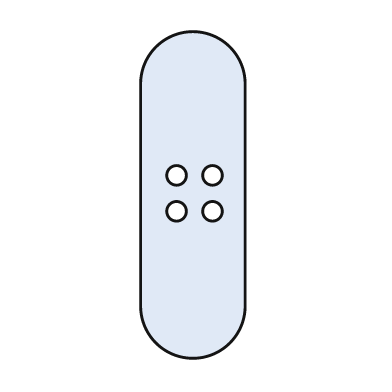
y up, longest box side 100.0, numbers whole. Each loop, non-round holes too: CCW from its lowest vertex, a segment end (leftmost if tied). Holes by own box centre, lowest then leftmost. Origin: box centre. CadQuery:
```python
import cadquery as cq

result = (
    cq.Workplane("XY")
    .moveTo(-16.0, -34.0)
    .threePointArc((0.0, -50.0), (16.0, -34.0))
    .lineTo(16.0, 34.0)
    .threePointArc((0.0, 50.0), (-16.0, 34.0))
    .close()
    .moveTo(-5.0, -5.0)
    .circle(3.0)
    .moveTo(6.0, -5.0)
    .circle(3.0)
    .moveTo(-5.0, 6.0)
    .circle(3.0)
    .moveTo(6.0, 6.0)
    .circle(3.0)
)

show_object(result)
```